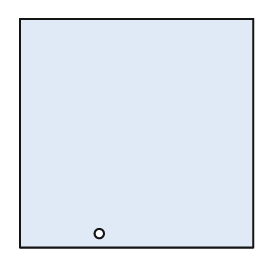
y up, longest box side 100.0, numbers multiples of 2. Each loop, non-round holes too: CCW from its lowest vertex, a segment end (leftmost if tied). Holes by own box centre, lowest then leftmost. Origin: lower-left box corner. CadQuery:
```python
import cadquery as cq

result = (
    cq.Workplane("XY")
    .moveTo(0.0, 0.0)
    .lineTo(100.0, 0.0)
    .lineTo(100.0, 98.0)
    .lineTo(0.0, 98.0)
    .close()
    .moveTo(34.0, 6.0)
    .circle(2.0)
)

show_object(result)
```